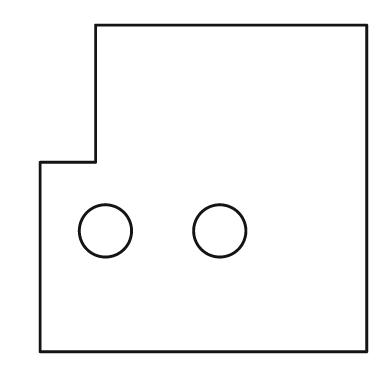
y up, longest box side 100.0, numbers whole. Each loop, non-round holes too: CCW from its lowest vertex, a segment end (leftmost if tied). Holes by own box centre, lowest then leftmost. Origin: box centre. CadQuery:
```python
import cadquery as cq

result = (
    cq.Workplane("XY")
    .moveTo(-50.0, -50.0)
    .lineTo(50.0, -50.0)
    .lineTo(50.0, 50.0)
    .lineTo(-33.0, 50.0)
    .lineTo(-33.0, 8.0)
    .lineTo(-50.0, 8.0)
    .close()
    .moveTo(-30.0, -13.0)
    .circle(8.0)
    .moveTo(5.0, -13.0)
    .circle(8.0)
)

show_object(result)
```